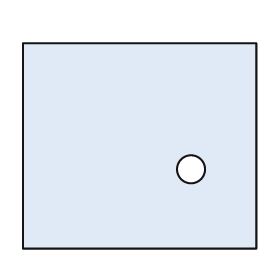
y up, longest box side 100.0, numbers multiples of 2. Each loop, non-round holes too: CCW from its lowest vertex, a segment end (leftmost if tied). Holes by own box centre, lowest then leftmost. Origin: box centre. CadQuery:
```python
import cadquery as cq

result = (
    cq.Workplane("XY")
    .moveTo(-50.0, -44.0)
    .lineTo(50.0, -44.0)
    .lineTo(50.0, 44.0)
    .lineTo(-50.0, 44.0)
    .close()
    .moveTo(22.0, -10.0)
    .circle(6.0)
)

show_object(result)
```